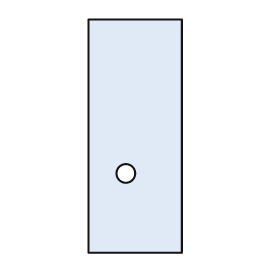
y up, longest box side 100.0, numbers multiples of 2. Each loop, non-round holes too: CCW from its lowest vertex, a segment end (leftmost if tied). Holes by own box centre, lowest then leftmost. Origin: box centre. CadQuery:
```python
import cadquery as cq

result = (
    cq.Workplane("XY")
    .moveTo(-20.0, -50.0)
    .lineTo(20.0, -50.0)
    .lineTo(20.0, 50.0)
    .lineTo(-20.0, 50.0)
    .close()
    .moveTo(-4.0, -16.0)
    .circle(4.0)
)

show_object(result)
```